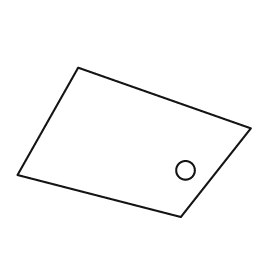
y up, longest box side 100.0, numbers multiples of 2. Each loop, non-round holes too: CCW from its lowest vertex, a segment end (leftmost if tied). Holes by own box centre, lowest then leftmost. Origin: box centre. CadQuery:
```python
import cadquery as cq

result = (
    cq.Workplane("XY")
    .moveTo(20.0, -32.0)
    .lineTo(50.0, 6.0)
    .lineTo(-24.0, 32.0)
    .lineTo(-50.0, -14.0)
    .close()
    .moveTo(22.0, -12.0)
    .circle(4.0)
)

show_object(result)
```